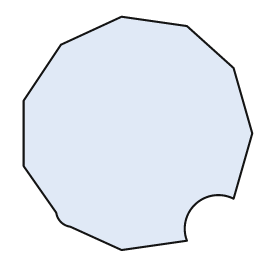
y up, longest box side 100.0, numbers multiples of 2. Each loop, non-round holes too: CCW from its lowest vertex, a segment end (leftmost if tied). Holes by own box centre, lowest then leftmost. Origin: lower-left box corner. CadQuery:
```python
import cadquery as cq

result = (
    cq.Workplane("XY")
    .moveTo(42.0, 0.0)
    .lineTo(70.0, 4.0)
    .threePointArc((74.0, 20.0), (90.0, 22.0))
    .lineTo(98.0, 50.0)
    .lineTo(90.0, 78.0)
    .lineTo(70.0, 96.0)
    .lineTo(42.0, 100.0)
    .lineTo(16.0, 88.0)
    .lineTo(0.0, 64.0)
    .lineTo(0.0, 36.0)
    .lineTo(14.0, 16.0)
    .threePointArc((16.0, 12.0), (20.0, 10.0))
    .close()
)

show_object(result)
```